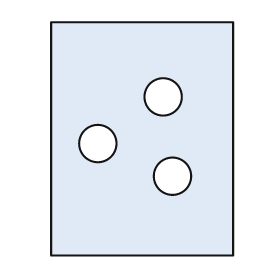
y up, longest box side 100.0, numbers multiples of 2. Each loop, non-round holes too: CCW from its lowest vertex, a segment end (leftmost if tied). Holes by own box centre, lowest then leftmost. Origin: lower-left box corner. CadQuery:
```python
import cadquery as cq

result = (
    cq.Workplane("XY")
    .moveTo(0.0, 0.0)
    .lineTo(78.0, 0.0)
    .lineTo(78.0, 100.0)
    .lineTo(0.0, 100.0)
    .close()
    .moveTo(52.0, 34.0)
    .circle(8.0)
    .moveTo(20.0, 48.0)
    .circle(8.0)
    .moveTo(48.0, 68.0)
    .circle(8.0)
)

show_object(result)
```